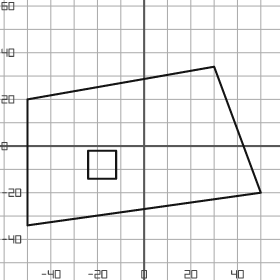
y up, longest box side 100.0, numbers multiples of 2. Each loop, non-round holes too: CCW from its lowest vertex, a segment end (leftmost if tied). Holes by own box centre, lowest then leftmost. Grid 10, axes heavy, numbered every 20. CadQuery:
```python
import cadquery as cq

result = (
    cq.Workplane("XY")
    .moveTo(-50.0, -34.0)
    .lineTo(50.0, -20.0)
    .lineTo(30.0, 34.0)
    .lineTo(-50.0, 20.0)
    .close()
    .moveTo(-24.0, -14.0)
    .lineTo(-12.0, -14.0)
    .lineTo(-12.0, -2.0)
    .lineTo(-24.0, -2.0)
    .close()
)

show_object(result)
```